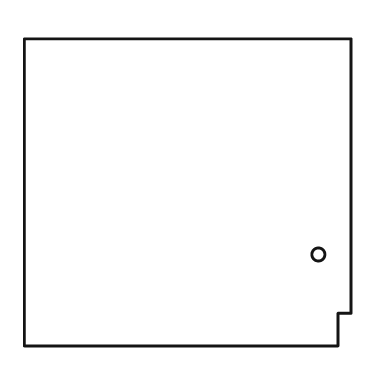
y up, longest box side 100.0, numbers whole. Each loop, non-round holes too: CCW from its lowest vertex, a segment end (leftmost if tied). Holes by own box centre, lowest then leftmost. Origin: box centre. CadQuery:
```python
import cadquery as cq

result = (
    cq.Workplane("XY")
    .moveTo(-50.0, -47.0)
    .lineTo(46.0, -47.0)
    .lineTo(46.0, -37.0)
    .lineTo(50.0, -37.0)
    .lineTo(50.0, 47.0)
    .lineTo(-50.0, 47.0)
    .close()
    .moveTo(40.0, -19.0)
    .circle(2.0)
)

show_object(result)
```